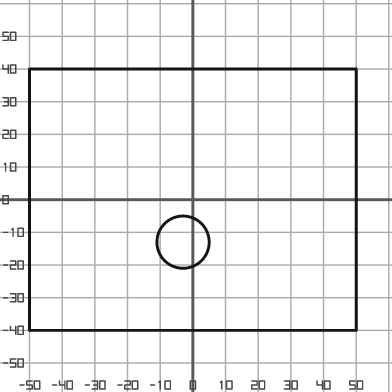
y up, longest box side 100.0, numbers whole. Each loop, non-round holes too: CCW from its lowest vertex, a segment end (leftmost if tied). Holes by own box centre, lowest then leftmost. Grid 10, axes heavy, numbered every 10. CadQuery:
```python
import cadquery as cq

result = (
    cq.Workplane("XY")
    .moveTo(-50.0, -40.0)
    .lineTo(50.0, -40.0)
    .lineTo(50.0, 40.0)
    .lineTo(-50.0, 40.0)
    .close()
    .moveTo(-3.0, -13.0)
    .circle(8.0)
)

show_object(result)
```